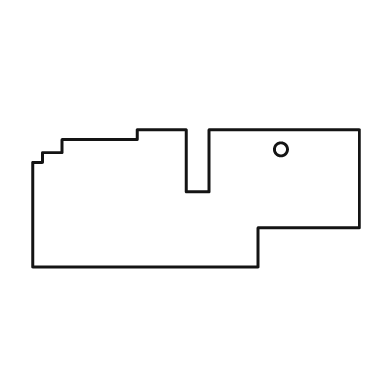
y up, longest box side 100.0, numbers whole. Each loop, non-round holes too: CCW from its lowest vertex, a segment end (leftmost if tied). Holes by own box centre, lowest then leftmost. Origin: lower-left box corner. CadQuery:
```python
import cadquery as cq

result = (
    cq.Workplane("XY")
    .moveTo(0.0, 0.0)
    .lineTo(69.0, 0.0)
    .lineTo(69.0, 12.0)
    .lineTo(100.0, 12.0)
    .lineTo(100.0, 42.0)
    .lineTo(54.0, 42.0)
    .lineTo(54.0, 23.0)
    .lineTo(47.0, 23.0)
    .lineTo(47.0, 42.0)
    .lineTo(32.0, 42.0)
    .lineTo(32.0, 39.0)
    .lineTo(9.0, 39.0)
    .lineTo(9.0, 35.0)
    .lineTo(3.0, 35.0)
    .lineTo(3.0, 32.0)
    .lineTo(0.0, 32.0)
    .close()
    .moveTo(76.0, 36.0)
    .circle(2.0)
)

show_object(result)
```